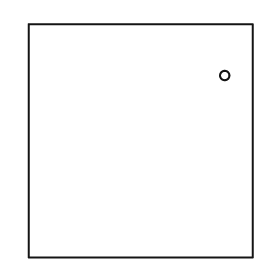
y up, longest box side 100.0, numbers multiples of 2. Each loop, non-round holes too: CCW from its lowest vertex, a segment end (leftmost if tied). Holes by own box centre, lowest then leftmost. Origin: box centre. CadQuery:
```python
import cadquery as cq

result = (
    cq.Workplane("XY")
    .moveTo(-48.0, -50.0)
    .lineTo(48.0, -50.0)
    .lineTo(48.0, 50.0)
    .lineTo(-48.0, 50.0)
    .close()
    .moveTo(36.0, 28.0)
    .circle(2.0)
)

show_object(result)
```